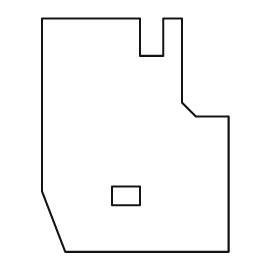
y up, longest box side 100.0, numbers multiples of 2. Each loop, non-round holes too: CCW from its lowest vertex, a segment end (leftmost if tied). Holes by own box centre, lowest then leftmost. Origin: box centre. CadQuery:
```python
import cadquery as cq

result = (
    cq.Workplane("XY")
    .moveTo(-30.0, -50.0)
    .lineTo(40.0, -50.0)
    .lineTo(40.0, 8.0)
    .lineTo(26.0, 8.0)
    .lineTo(20.0, 14.0)
    .lineTo(20.0, 50.0)
    .lineTo(12.0, 50.0)
    .lineTo(12.0, 34.0)
    .lineTo(2.0, 34.0)
    .lineTo(2.0, 50.0)
    .lineTo(-40.0, 50.0)
    .lineTo(-40.0, -24.0)
    .close()
    .moveTo(-10.0, -30.0)
    .lineTo(2.0, -30.0)
    .lineTo(2.0, -22.0)
    .lineTo(-10.0, -22.0)
    .close()
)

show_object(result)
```